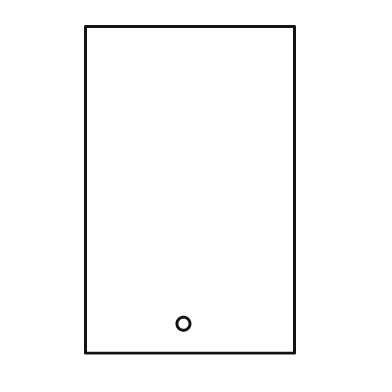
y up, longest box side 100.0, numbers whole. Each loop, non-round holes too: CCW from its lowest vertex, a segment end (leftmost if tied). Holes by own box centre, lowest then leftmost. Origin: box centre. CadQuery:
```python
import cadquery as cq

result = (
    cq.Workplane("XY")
    .moveTo(-32.0, -50.0)
    .lineTo(32.0, -50.0)
    .lineTo(32.0, 50.0)
    .lineTo(-32.0, 50.0)
    .close()
    .moveTo(-2.0, -41.0)
    .circle(2.0)
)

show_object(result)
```